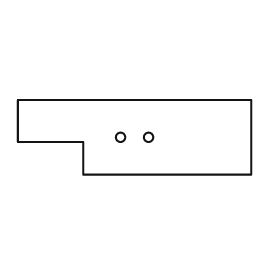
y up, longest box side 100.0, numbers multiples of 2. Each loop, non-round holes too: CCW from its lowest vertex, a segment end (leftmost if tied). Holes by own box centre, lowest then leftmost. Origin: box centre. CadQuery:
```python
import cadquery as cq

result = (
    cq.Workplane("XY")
    .moveTo(-22.0, -16.0)
    .lineTo(50.0, -16.0)
    .lineTo(50.0, 16.0)
    .lineTo(-50.0, 16.0)
    .lineTo(-50.0, -2.0)
    .lineTo(-22.0, -2.0)
    .close()
    .moveTo(-6.0, 0.0)
    .circle(2.0)
    .moveTo(6.0, 0.0)
    .circle(2.0)
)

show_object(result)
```